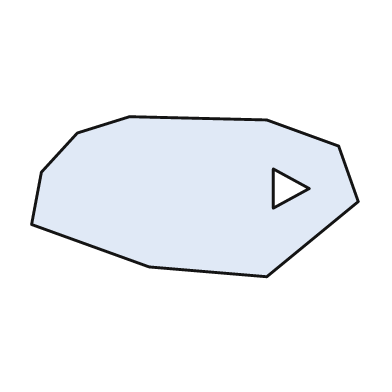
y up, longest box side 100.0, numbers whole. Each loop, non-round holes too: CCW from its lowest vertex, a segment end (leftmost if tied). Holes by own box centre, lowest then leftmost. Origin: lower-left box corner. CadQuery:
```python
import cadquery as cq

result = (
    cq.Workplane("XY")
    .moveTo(72.0, 0.0)
    .lineTo(100.0, 23.0)
    .lineTo(94.0, 40.0)
    .lineTo(72.0, 48.0)
    .lineTo(30.0, 49.0)
    .lineTo(14.0, 44.0)
    .lineTo(3.0, 32.0)
    .lineTo(0.0, 16.0)
    .lineTo(36.0, 3.0)
    .close()
    .moveTo(74.0, 21.0)
    .lineTo(85.0, 27.0)
    .lineTo(74.0, 33.0)
    .close()
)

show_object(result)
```